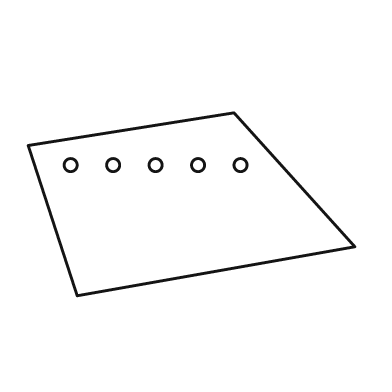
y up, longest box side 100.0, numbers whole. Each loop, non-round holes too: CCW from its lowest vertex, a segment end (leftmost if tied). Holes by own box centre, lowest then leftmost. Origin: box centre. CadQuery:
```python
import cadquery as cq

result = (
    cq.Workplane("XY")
    .moveTo(-35.0, -28.0)
    .lineTo(50.0, -13.0)
    .lineTo(13.0, 28.0)
    .lineTo(-50.0, 18.0)
    .close()
    .moveTo(-37.0, 12.0)
    .circle(2.0)
    .moveTo(-24.0, 12.0)
    .circle(2.0)
    .moveTo(-11.0, 12.0)
    .circle(2.0)
    .moveTo(2.0, 12.0)
    .circle(2.0)
    .moveTo(15.0, 12.0)
    .circle(2.0)
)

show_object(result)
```